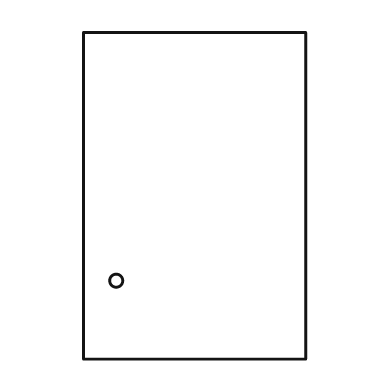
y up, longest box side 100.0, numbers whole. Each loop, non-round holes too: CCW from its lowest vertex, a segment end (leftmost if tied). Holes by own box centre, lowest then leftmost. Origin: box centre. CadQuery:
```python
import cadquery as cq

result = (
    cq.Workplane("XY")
    .moveTo(-34.0, -50.0)
    .lineTo(34.0, -50.0)
    .lineTo(34.0, 50.0)
    .lineTo(-34.0, 50.0)
    .close()
    .moveTo(-24.0, -26.0)
    .circle(2.0)
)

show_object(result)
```